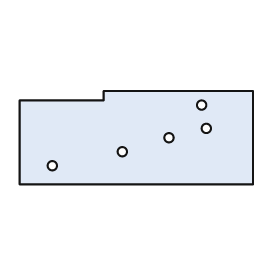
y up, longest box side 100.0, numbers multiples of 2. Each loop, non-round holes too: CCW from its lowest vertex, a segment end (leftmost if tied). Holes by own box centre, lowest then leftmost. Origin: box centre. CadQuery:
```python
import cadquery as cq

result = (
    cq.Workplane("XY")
    .moveTo(-50.0, -20.0)
    .lineTo(50.0, -20.0)
    .lineTo(50.0, 20.0)
    .lineTo(-14.0, 20.0)
    .lineTo(-14.0, 16.0)
    .lineTo(-50.0, 16.0)
    .close()
    .moveTo(-36.0, -12.0)
    .circle(2.0)
    .moveTo(-6.0, -6.0)
    .circle(2.0)
    .moveTo(14.0, 0.0)
    .circle(2.0)
    .moveTo(30.0, 4.0)
    .circle(2.0)
    .moveTo(28.0, 14.0)
    .circle(2.0)
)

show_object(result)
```